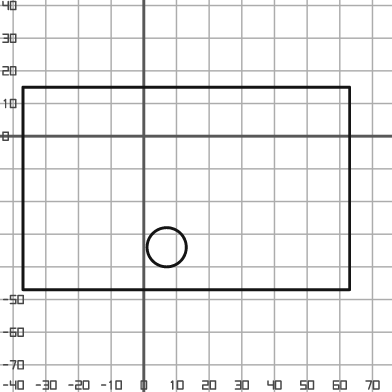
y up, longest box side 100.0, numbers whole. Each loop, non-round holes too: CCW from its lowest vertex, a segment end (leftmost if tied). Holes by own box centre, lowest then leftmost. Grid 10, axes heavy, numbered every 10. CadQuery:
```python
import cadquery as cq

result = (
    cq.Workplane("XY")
    .moveTo(-37.0, -47.0)
    .lineTo(63.0, -47.0)
    .lineTo(63.0, 15.0)
    .lineTo(-37.0, 15.0)
    .close()
    .moveTo(7.0, -34.0)
    .circle(6.0)
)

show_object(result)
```